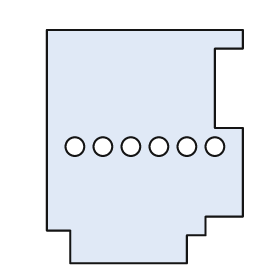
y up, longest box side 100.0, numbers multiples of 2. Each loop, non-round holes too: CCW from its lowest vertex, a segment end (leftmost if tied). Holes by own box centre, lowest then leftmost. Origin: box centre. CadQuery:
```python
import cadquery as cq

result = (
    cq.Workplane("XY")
    .moveTo(-32.0, -50.0)
    .lineTo(18.0, -50.0)
    .lineTo(18.0, -38.0)
    .lineTo(26.0, -38.0)
    .lineTo(26.0, -30.0)
    .lineTo(42.0, -30.0)
    .lineTo(42.0, 8.0)
    .lineTo(30.0, 8.0)
    .lineTo(30.0, 42.0)
    .lineTo(42.0, 42.0)
    .lineTo(42.0, 50.0)
    .lineTo(-42.0, 50.0)
    .lineTo(-42.0, -36.0)
    .lineTo(-32.0, -36.0)
    .close()
    .moveTo(-30.0, 0.0)
    .circle(4.0)
    .moveTo(-18.0, 0.0)
    .circle(4.0)
    .moveTo(-6.0, 0.0)
    .circle(4.0)
    .moveTo(6.0, 0.0)
    .circle(4.0)
    .moveTo(18.0, 0.0)
    .circle(4.0)
    .moveTo(30.0, 0.0)
    .circle(4.0)
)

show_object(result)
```